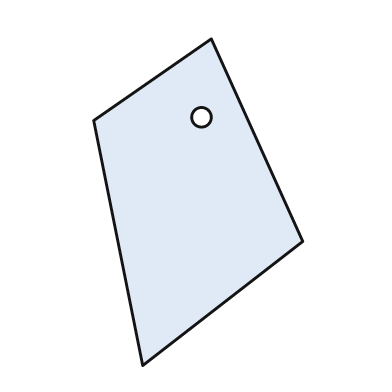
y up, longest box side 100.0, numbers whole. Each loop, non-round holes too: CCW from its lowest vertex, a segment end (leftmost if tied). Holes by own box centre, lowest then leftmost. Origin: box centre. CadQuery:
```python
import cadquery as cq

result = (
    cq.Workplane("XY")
    .moveTo(-17.0, -50.0)
    .lineTo(32.0, -12.0)
    .lineTo(4.0, 50.0)
    .lineTo(-32.0, 25.0)
    .close()
    .moveTo(1.0, 26.0)
    .circle(3.0)
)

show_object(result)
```